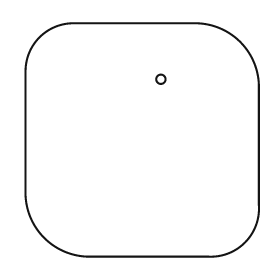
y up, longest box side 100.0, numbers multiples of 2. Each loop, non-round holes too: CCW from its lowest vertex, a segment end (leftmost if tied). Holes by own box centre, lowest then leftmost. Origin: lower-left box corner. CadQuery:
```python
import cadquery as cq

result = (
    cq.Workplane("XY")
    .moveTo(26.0, 0.0)
    .lineTo(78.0, 0.0)
    .threePointArc((94.0, 6.0), (100.0, 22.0))
    .lineTo(100.0, 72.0)
    .threePointArc((92.0, 92.0), (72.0, 100.0))
    .lineTo(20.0, 100.0)
    .threePointArc((6.0, 94.0), (0.0, 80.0))
    .lineTo(0.0, 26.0)
    .threePointArc((8.0, 8.0), (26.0, 0.0))
    .close()
    .moveTo(58.0, 76.0)
    .circle(2.0)
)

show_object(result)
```